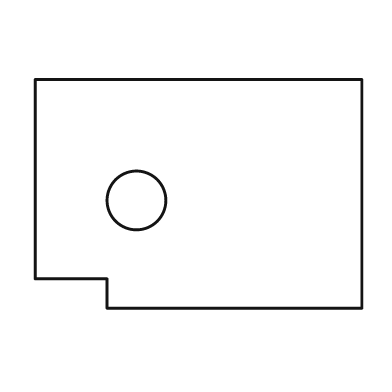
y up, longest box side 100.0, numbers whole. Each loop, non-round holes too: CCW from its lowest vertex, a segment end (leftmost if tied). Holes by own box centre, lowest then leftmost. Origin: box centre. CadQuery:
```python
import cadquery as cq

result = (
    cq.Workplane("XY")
    .moveTo(-28.0, -35.0)
    .lineTo(50.0, -35.0)
    .lineTo(50.0, 35.0)
    .lineTo(-50.0, 35.0)
    .lineTo(-50.0, -26.0)
    .lineTo(-28.0, -26.0)
    .close()
    .moveTo(-19.0, -2.0)
    .circle(9.0)
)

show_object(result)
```